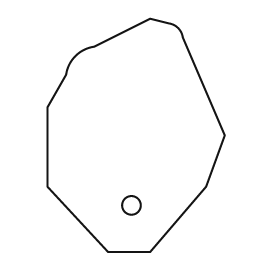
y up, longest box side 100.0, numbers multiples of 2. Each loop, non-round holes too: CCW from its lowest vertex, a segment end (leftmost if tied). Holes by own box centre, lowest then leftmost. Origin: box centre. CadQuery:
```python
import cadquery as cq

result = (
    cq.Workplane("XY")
    .moveTo(-12.0, -50.0)
    .lineTo(6.0, -50.0)
    .lineTo(30.0, -22.0)
    .lineTo(38.0, 0.0)
    .lineTo(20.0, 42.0)
    .threePointArc((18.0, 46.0), (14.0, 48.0))
    .lineTo(6.0, 50.0)
    .lineTo(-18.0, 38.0)
    .threePointArc((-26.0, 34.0), (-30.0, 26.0))
    .lineTo(-38.0, 12.0)
    .lineTo(-38.0, -22.0)
    .close()
    .moveTo(-2.0, -30.0)
    .circle(4.0)
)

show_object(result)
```